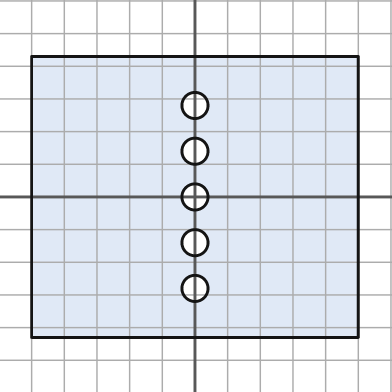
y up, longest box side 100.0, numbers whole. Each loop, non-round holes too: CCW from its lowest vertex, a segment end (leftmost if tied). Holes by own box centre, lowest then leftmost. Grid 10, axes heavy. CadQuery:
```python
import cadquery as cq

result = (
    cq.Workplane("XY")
    .moveTo(-50.0, -43.0)
    .lineTo(50.0, -43.0)
    .lineTo(50.0, 43.0)
    .lineTo(-50.0, 43.0)
    .close()
    .moveTo(0.0, -28.0)
    .circle(4.0)
    .moveTo(0.0, -14.0)
    .circle(4.0)
    .moveTo(0.0, 0.0)
    .circle(4.0)
    .moveTo(0.0, 14.0)
    .circle(4.0)
    .moveTo(0.0, 28.0)
    .circle(4.0)
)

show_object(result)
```